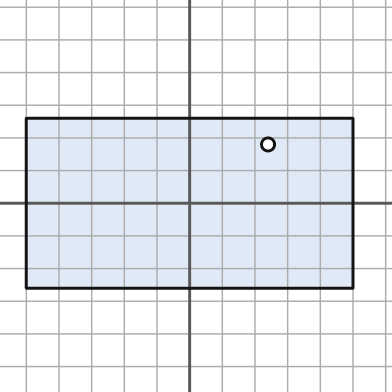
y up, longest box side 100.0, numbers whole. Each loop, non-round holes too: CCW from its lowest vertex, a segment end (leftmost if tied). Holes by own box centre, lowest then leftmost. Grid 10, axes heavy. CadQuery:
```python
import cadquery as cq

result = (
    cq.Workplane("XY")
    .moveTo(-50.0, -26.0)
    .lineTo(50.0, -26.0)
    .lineTo(50.0, 26.0)
    .lineTo(-50.0, 26.0)
    .close()
    .moveTo(24.0, 18.0)
    .circle(2.0)
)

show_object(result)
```